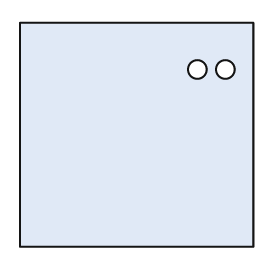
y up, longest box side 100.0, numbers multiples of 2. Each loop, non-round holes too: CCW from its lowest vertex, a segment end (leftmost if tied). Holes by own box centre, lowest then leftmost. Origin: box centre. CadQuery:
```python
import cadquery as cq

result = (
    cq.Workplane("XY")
    .moveTo(-50.0, -48.0)
    .lineTo(50.0, -48.0)
    .lineTo(50.0, 48.0)
    .lineTo(-50.0, 48.0)
    .close()
    .moveTo(26.0, 28.0)
    .circle(4.0)
    .moveTo(38.0, 28.0)
    .circle(4.0)
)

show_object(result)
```